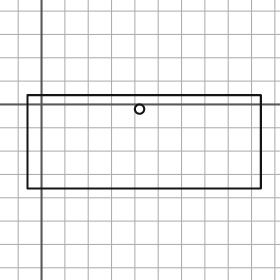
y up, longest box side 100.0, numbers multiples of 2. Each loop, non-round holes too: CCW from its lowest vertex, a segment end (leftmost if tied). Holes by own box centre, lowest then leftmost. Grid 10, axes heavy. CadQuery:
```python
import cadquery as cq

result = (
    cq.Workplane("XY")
    .moveTo(-6.0, -36.0)
    .lineTo(94.0, -36.0)
    .lineTo(94.0, 4.0)
    .lineTo(-6.0, 4.0)
    .close()
    .moveTo(42.0, -2.0)
    .circle(2.0)
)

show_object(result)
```